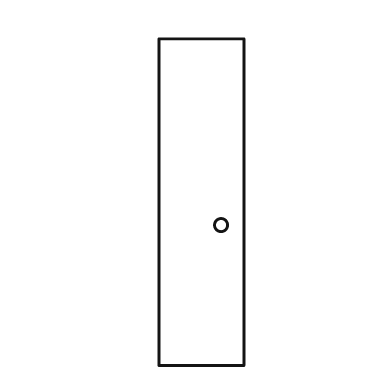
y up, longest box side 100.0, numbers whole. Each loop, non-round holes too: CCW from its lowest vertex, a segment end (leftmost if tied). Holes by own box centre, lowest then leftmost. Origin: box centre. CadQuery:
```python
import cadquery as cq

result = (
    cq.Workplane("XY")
    .moveTo(-13.0, -50.0)
    .lineTo(13.0, -50.0)
    .lineTo(13.0, 50.0)
    .lineTo(-13.0, 50.0)
    .close()
    .moveTo(6.0, -7.0)
    .circle(2.0)
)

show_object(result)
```